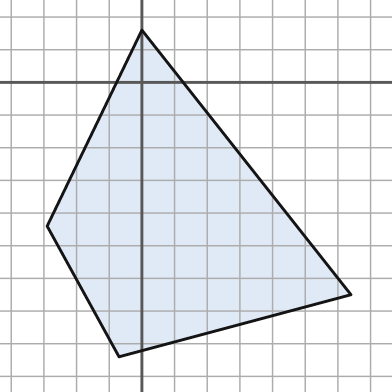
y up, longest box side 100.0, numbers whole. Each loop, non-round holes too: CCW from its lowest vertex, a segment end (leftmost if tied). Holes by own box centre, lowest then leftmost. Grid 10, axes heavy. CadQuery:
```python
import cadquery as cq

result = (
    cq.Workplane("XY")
    .moveTo(-7.0, -84.0)
    .lineTo(64.0, -65.0)
    .lineTo(0.0, 16.0)
    .lineTo(-29.0, -44.0)
    .close()
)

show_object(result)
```